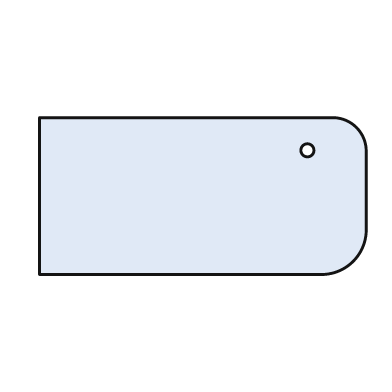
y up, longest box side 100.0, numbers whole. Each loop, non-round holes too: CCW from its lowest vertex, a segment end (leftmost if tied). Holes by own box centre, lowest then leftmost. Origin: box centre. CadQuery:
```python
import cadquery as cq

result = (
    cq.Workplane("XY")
    .moveTo(-50.0, -24.0)
    .lineTo(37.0, -24.0)
    .threePointArc((46.0, -20.0), (50.0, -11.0))
    .lineTo(50.0, 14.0)
    .threePointArc((47.0, 21.0), (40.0, 24.0))
    .lineTo(-50.0, 24.0)
    .close()
    .moveTo(32.0, 14.0)
    .circle(2.0)
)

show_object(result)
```